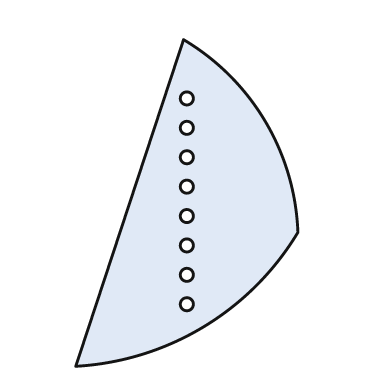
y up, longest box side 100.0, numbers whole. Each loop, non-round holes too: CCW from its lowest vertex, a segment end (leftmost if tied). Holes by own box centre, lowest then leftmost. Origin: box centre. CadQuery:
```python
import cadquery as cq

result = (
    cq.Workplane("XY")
    .moveTo(-34.0, -50.0)
    .threePointArc((5.0, -38.0), (34.0, -9.0))
    .threePointArc((24.0, 25.0), (-1.0, 50.0))
    .close()
    .moveTo(0.0, -31.0)
    .circle(2.0)
    .moveTo(0.0, -22.0)
    .circle(2.0)
    .moveTo(0.0, -13.0)
    .circle(2.0)
    .moveTo(0.0, -4.0)
    .circle(2.0)
    .moveTo(0.0, 5.0)
    .circle(2.0)
    .moveTo(0.0, 14.0)
    .circle(2.0)
    .moveTo(0.0, 23.0)
    .circle(2.0)
    .moveTo(0.0, 32.0)
    .circle(2.0)
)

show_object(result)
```